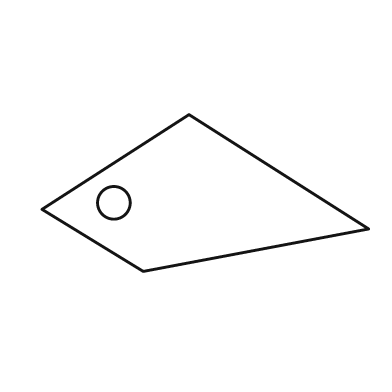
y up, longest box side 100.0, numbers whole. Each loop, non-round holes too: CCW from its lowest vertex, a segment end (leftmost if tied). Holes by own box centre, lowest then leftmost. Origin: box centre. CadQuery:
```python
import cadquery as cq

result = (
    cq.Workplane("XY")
    .moveTo(-19.0, -24.0)
    .lineTo(50.0, -11.0)
    .lineTo(-5.0, 24.0)
    .lineTo(-50.0, -5.0)
    .close()
    .moveTo(-28.0, -3.0)
    .circle(5.0)
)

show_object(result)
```